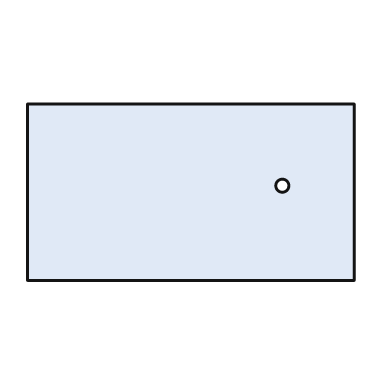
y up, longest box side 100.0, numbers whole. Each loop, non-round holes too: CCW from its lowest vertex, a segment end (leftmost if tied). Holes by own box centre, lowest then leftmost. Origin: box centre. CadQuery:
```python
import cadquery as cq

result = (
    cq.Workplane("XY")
    .moveTo(-50.0, -27.0)
    .lineTo(50.0, -27.0)
    .lineTo(50.0, 27.0)
    .lineTo(-50.0, 27.0)
    .close()
    .moveTo(28.0, 2.0)
    .circle(2.0)
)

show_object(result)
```